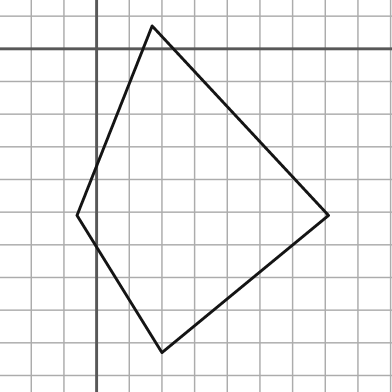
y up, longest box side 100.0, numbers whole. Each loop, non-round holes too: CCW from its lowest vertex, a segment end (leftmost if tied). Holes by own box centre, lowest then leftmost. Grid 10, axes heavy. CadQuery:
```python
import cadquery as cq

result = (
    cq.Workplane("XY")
    .moveTo(20.0, -93.0)
    .lineTo(71.0, -51.0)
    .lineTo(17.0, 7.0)
    .lineTo(-6.0, -51.0)
    .close()
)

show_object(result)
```